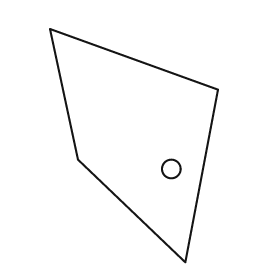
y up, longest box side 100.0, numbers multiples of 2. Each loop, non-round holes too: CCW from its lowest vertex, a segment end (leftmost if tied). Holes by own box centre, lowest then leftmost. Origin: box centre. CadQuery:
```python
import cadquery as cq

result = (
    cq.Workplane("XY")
    .moveTo(22.0, -50.0)
    .lineTo(36.0, 24.0)
    .lineTo(-36.0, 50.0)
    .lineTo(-24.0, -6.0)
    .close()
    .moveTo(16.0, -10.0)
    .circle(4.0)
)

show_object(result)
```